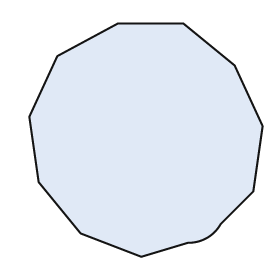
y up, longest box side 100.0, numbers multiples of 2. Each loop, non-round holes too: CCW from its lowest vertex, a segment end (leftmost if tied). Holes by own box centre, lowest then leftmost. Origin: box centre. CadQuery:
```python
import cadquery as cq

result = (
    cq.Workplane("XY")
    .moveTo(-2.0, -50.0)
    .lineTo(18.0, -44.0)
    .threePointArc((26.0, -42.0), (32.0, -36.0))
    .lineTo(46.0, -22.0)
    .lineTo(50.0, 6.0)
    .lineTo(38.0, 32.0)
    .lineTo(16.0, 50.0)
    .lineTo(-12.0, 50.0)
    .lineTo(-38.0, 36.0)
    .lineTo(-50.0, 10.0)
    .lineTo(-46.0, -18.0)
    .lineTo(-28.0, -40.0)
    .close()
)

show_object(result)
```